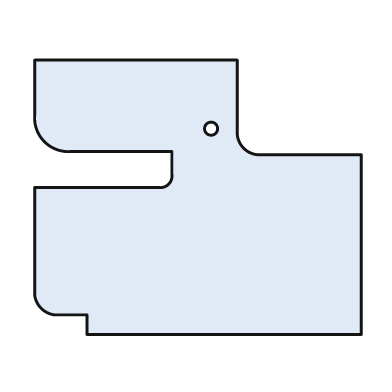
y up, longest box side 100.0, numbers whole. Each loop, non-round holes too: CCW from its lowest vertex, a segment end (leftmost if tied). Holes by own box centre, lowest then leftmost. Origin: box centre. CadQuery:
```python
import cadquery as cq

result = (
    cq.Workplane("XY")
    .moveTo(-34.0, -42.0)
    .lineTo(50.0, -42.0)
    .lineTo(50.0, 13.0)
    .lineTo(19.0, 13.0)
    .threePointArc((14.0, 15.0), (12.0, 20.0))
    .lineTo(12.0, 42.0)
    .lineTo(-50.0, 42.0)
    .lineTo(-50.0, 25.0)
    .threePointArc((-47.0, 17.0), (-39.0, 14.0))
    .lineTo(-8.0, 14.0)
    .lineTo(-8.0, 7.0)
    .threePointArc((-9.0, 4.0), (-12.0, 3.0))
    .lineTo(-50.0, 3.0)
    .lineTo(-50.0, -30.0)
    .threePointArc((-48.0, -34.0), (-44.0, -36.0))
    .lineTo(-34.0, -36.0)
    .close()
    .moveTo(4.0, 21.0)
    .circle(2.0)
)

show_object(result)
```